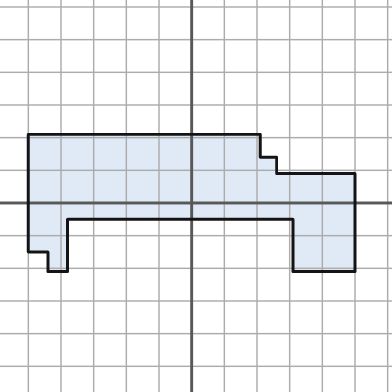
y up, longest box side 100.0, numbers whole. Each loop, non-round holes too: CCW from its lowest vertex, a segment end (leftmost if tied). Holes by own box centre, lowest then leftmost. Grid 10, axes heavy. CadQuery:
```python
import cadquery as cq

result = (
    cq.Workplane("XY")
    .moveTo(-44.0, -21.0)
    .lineTo(-38.0, -21.0)
    .lineTo(-38.0, -5.0)
    .lineTo(31.0, -5.0)
    .lineTo(31.0, -21.0)
    .lineTo(50.0, -21.0)
    .lineTo(50.0, 9.0)
    .lineTo(26.0, 9.0)
    .lineTo(26.0, 14.0)
    .lineTo(21.0, 14.0)
    .lineTo(21.0, 21.0)
    .lineTo(-50.0, 21.0)
    .lineTo(-50.0, -15.0)
    .lineTo(-44.0, -15.0)
    .close()
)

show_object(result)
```